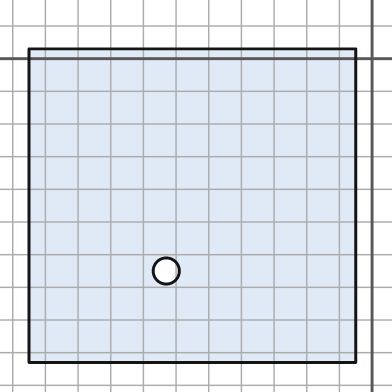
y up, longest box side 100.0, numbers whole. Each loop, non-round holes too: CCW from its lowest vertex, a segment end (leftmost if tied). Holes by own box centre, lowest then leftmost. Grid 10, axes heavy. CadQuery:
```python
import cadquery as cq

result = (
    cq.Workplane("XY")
    .moveTo(-105.0, -93.0)
    .lineTo(-5.0, -93.0)
    .lineTo(-5.0, 3.0)
    .lineTo(-105.0, 3.0)
    .close()
    .moveTo(-63.0, -65.0)
    .circle(4.0)
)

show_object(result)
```